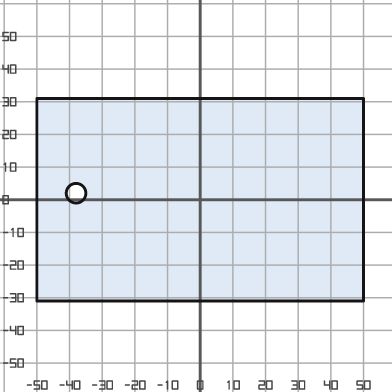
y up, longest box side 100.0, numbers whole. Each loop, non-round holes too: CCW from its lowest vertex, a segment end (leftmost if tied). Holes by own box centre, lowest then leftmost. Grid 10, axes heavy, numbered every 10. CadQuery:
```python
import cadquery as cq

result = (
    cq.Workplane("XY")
    .moveTo(-50.0, -31.0)
    .lineTo(50.0, -31.0)
    .lineTo(50.0, 31.0)
    .lineTo(-50.0, 31.0)
    .close()
    .moveTo(-38.0, 2.0)
    .circle(3.0)
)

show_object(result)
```